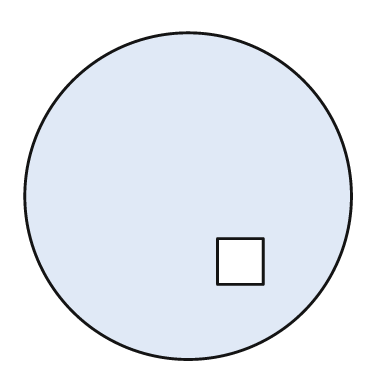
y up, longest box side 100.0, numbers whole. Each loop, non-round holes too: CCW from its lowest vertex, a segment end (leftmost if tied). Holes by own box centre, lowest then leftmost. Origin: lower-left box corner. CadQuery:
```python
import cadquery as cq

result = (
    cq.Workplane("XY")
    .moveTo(50.0, 50.0)
    .circle(50.0)
    .moveTo(59.0, 23.0)
    .lineTo(73.0, 23.0)
    .lineTo(73.0, 37.0)
    .lineTo(59.0, 37.0)
    .close()
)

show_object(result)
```